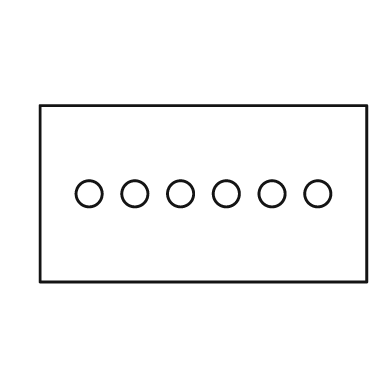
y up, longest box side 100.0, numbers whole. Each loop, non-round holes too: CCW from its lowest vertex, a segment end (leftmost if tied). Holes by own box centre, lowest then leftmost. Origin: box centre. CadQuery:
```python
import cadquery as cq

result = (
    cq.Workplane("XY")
    .moveTo(-50.0, -27.0)
    .lineTo(50.0, -27.0)
    .lineTo(50.0, 27.0)
    .lineTo(-50.0, 27.0)
    .close()
    .moveTo(-35.0, 0.0)
    .circle(4.0)
    .moveTo(-21.0, 0.0)
    .circle(4.0)
    .moveTo(-7.0, 0.0)
    .circle(4.0)
    .moveTo(7.0, 0.0)
    .circle(4.0)
    .moveTo(21.0, 0.0)
    .circle(4.0)
    .moveTo(35.0, 0.0)
    .circle(4.0)
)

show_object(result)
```